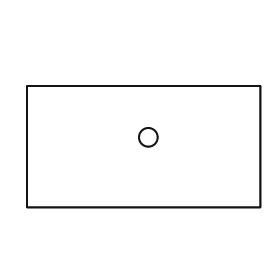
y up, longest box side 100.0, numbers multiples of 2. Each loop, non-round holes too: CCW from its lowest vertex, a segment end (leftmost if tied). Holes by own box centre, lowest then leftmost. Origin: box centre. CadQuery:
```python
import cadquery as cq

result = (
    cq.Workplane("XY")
    .moveTo(-50.0, -26.0)
    .lineTo(50.0, -26.0)
    .lineTo(50.0, 26.0)
    .lineTo(-50.0, 26.0)
    .close()
    .moveTo(2.0, 4.0)
    .circle(4.0)
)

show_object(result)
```